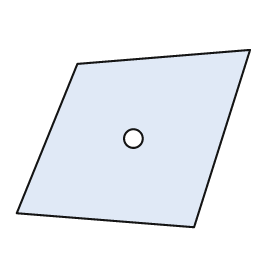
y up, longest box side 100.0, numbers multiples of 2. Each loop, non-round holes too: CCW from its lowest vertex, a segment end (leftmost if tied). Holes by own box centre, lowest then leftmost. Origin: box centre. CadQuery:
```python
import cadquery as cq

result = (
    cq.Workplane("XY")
    .moveTo(26.0, -38.0)
    .lineTo(50.0, 38.0)
    .lineTo(-24.0, 32.0)
    .lineTo(-50.0, -32.0)
    .close()
    .moveTo(0.0, 0.0)
    .circle(4.0)
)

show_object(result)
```